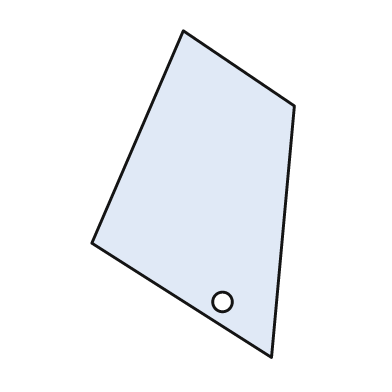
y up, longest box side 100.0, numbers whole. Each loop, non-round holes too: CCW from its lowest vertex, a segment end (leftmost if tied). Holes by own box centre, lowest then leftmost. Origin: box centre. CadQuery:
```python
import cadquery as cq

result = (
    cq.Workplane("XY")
    .moveTo(24.0, -50.0)
    .lineTo(31.0, 27.0)
    .lineTo(-3.0, 50.0)
    .lineTo(-31.0, -15.0)
    .close()
    .moveTo(9.0, -33.0)
    .circle(3.0)
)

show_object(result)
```